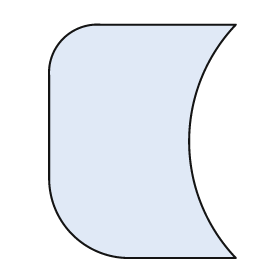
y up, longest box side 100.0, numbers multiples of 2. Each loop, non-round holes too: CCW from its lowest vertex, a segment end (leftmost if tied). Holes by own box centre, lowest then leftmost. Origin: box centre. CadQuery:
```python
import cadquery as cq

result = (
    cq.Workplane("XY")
    .moveTo(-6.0, -50.0)
    .lineTo(40.0, -50.0)
    .threePointArc((20.0, 0.0), (40.0, 50.0))
    .lineTo(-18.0, 50.0)
    .threePointArc((-34.0, 44.0), (-40.0, 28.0))
    .lineTo(-40.0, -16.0)
    .threePointArc((-30.0, -40.0), (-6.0, -50.0))
    .close()
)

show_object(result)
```